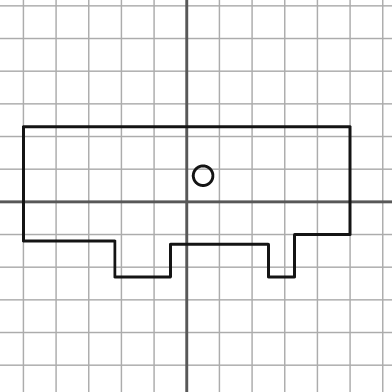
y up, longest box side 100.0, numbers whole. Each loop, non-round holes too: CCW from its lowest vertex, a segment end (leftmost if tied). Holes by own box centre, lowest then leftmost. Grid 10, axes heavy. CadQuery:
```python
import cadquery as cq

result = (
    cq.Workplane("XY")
    .moveTo(-22.0, -23.0)
    .lineTo(-5.0, -23.0)
    .lineTo(-5.0, -13.0)
    .lineTo(25.0, -13.0)
    .lineTo(25.0, -23.0)
    .lineTo(33.0, -23.0)
    .lineTo(33.0, -10.0)
    .lineTo(50.0, -10.0)
    .lineTo(50.0, 23.0)
    .lineTo(-50.0, 23.0)
    .lineTo(-50.0, -12.0)
    .lineTo(-22.0, -12.0)
    .close()
    .moveTo(5.0, 8.0)
    .circle(3.0)
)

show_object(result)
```